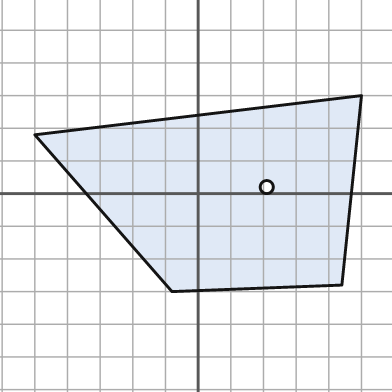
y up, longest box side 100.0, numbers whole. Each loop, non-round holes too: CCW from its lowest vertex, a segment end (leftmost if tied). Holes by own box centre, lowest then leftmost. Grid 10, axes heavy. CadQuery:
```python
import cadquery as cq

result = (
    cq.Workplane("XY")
    .moveTo(-8.0, -30.0)
    .lineTo(44.0, -28.0)
    .lineTo(50.0, 30.0)
    .lineTo(-50.0, 18.0)
    .close()
    .moveTo(21.0, 2.0)
    .circle(2.0)
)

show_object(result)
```